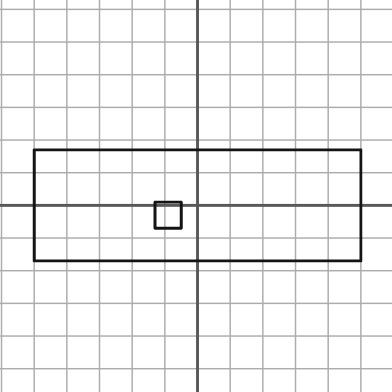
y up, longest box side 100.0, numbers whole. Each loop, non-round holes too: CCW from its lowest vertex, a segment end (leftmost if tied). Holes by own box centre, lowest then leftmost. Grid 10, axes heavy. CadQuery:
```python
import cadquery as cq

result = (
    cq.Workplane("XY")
    .moveTo(-50.0, -17.0)
    .lineTo(50.0, -17.0)
    .lineTo(50.0, 17.0)
    .lineTo(-50.0, 17.0)
    .close()
    .moveTo(-13.0, -7.0)
    .lineTo(-5.0, -7.0)
    .lineTo(-5.0, 1.0)
    .lineTo(-13.0, 1.0)
    .close()
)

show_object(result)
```